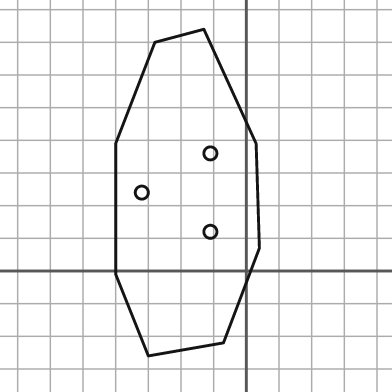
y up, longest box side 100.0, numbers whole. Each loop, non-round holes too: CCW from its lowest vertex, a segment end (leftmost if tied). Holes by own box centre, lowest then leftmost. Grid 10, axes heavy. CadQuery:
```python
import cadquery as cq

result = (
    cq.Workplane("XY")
    .moveTo(-30.0, -26.0)
    .lineTo(-7.0, -22.0)
    .lineTo(4.0, 7.0)
    .lineTo(3.0, 39.0)
    .lineTo(-13.0, 74.0)
    .lineTo(-28.0, 70.0)
    .lineTo(-40.0, 39.0)
    .lineTo(-40.0, -1.0)
    .close()
    .moveTo(-11.0, 12.0)
    .circle(2.0)
    .moveTo(-32.0, 24.0)
    .circle(2.0)
    .moveTo(-11.0, 36.0)
    .circle(2.0)
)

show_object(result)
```